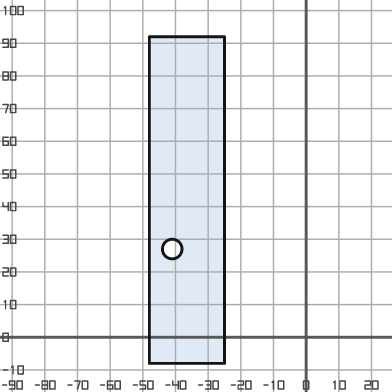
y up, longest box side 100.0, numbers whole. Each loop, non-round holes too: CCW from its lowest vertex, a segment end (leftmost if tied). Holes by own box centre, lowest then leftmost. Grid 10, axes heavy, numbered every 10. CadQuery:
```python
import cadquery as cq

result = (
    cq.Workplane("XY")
    .moveTo(-48.0, -8.0)
    .lineTo(-25.0, -8.0)
    .lineTo(-25.0, 92.0)
    .lineTo(-48.0, 92.0)
    .close()
    .moveTo(-41.0, 27.0)
    .circle(3.0)
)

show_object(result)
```